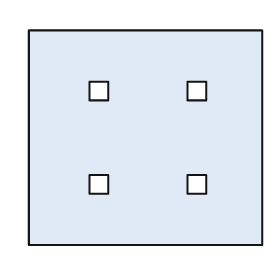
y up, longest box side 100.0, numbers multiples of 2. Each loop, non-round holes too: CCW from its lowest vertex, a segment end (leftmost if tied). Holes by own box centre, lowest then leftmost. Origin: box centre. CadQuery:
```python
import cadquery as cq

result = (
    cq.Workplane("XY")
    .moveTo(-50.0, -46.0)
    .lineTo(50.0, -46.0)
    .lineTo(50.0, 46.0)
    .lineTo(-50.0, 46.0)
    .close()
    .moveTo(-24.0, -24.0)
    .lineTo(-16.0, -24.0)
    .lineTo(-16.0, -16.0)
    .lineTo(-24.0, -16.0)
    .close()
    .moveTo(18.0, -24.0)
    .lineTo(26.0, -24.0)
    .lineTo(26.0, -16.0)
    .lineTo(18.0, -16.0)
    .close()
    .moveTo(-24.0, 16.0)
    .lineTo(-16.0, 16.0)
    .lineTo(-16.0, 24.0)
    .lineTo(-24.0, 24.0)
    .close()
    .moveTo(18.0, 16.0)
    .lineTo(26.0, 16.0)
    .lineTo(26.0, 24.0)
    .lineTo(18.0, 24.0)
    .close()
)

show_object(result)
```